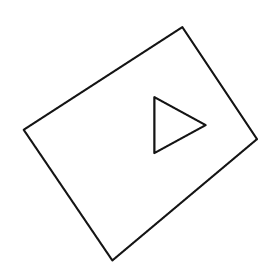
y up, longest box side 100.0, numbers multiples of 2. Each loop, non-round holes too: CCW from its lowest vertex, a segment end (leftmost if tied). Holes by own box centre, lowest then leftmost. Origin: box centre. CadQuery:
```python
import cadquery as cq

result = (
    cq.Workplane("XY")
    .moveTo(-12.0, -50.0)
    .lineTo(50.0, 2.0)
    .lineTo(18.0, 50.0)
    .lineTo(-50.0, 6.0)
    .close()
    .moveTo(6.0, -4.0)
    .lineTo(28.0, 8.0)
    .lineTo(6.0, 20.0)
    .close()
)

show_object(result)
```